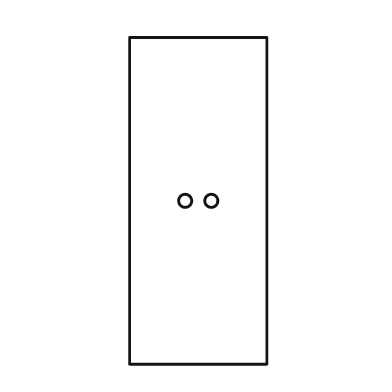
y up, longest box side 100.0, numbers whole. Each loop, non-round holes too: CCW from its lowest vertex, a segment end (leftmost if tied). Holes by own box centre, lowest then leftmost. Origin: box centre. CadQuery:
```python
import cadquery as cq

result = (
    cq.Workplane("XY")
    .moveTo(-21.0, -50.0)
    .lineTo(21.0, -50.0)
    .lineTo(21.0, 50.0)
    .lineTo(-21.0, 50.0)
    .close()
    .moveTo(-4.0, 0.0)
    .circle(2.0)
    .moveTo(4.0, 0.0)
    .circle(2.0)
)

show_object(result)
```